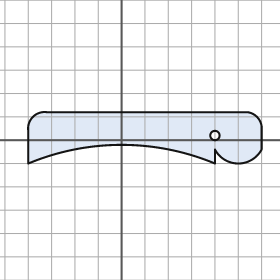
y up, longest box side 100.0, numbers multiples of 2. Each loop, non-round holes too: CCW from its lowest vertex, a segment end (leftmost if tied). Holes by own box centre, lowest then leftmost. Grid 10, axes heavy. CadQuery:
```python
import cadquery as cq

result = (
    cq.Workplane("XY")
    .moveTo(-40.0, -10.0)
    .threePointArc((0.0, -2.0), (40.0, -10.0))
    .lineTo(40.0, -4.0)
    .threePointArc((50.0, -10.0), (60.0, -4.0))
    .lineTo(60.0, 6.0)
    .threePointArc((58.0, 10.0), (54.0, 12.0))
    .lineTo(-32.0, 12.0)
    .threePointArc((-38.0, 10.0), (-40.0, 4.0))
    .close()
    .moveTo(40.0, 2.0)
    .circle(2.0)
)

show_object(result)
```